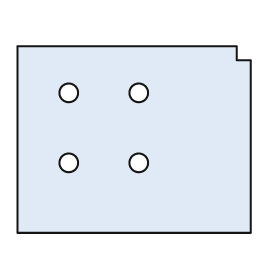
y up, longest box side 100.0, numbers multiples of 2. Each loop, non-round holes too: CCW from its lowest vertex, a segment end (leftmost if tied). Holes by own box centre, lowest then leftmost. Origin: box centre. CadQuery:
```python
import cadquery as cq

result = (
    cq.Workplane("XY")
    .moveTo(-50.0, -40.0)
    .lineTo(50.0, -40.0)
    .lineTo(50.0, 34.0)
    .lineTo(44.0, 34.0)
    .lineTo(44.0, 40.0)
    .lineTo(-50.0, 40.0)
    .close()
    .moveTo(-28.0, -10.0)
    .circle(4.0)
    .moveTo(2.0, -10.0)
    .circle(4.0)
    .moveTo(-28.0, 20.0)
    .circle(4.0)
    .moveTo(2.0, 20.0)
    .circle(4.0)
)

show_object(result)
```